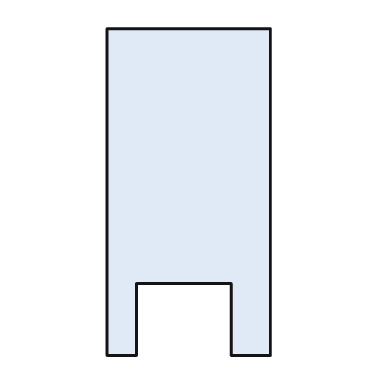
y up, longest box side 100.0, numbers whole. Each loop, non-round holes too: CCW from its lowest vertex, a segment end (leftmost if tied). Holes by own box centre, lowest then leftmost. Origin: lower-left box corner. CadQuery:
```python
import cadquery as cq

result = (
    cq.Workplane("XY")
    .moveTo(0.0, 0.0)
    .lineTo(9.0, 0.0)
    .lineTo(9.0, 22.0)
    .lineTo(38.0, 22.0)
    .lineTo(38.0, 0.0)
    .lineTo(50.0, 0.0)
    .lineTo(50.0, 100.0)
    .lineTo(0.0, 100.0)
    .close()
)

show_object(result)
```